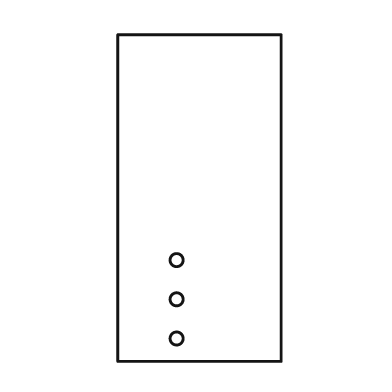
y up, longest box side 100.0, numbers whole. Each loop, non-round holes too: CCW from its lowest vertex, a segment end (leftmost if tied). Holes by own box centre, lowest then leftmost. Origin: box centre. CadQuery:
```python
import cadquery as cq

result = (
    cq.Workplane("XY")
    .moveTo(-25.0, -50.0)
    .lineTo(25.0, -50.0)
    .lineTo(25.0, 50.0)
    .lineTo(-25.0, 50.0)
    .close()
    .moveTo(-7.0, -43.0)
    .circle(2.0)
    .moveTo(-7.0, -31.0)
    .circle(2.0)
    .moveTo(-7.0, -19.0)
    .circle(2.0)
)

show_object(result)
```